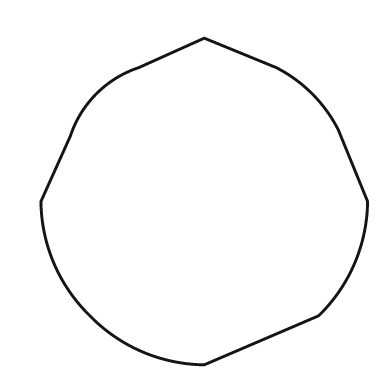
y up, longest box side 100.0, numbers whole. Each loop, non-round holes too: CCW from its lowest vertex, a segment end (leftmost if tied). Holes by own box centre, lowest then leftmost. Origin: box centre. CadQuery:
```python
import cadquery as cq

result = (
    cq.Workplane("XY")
    .moveTo(0.0, -50.0)
    .lineTo(35.0, -35.0)
    .threePointArc((46.0, -19.0), (50.0, 0.0))
    .lineTo(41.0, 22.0)
    .threePointArc((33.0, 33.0), (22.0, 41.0))
    .lineTo(0.0, 50.0)
    .lineTo(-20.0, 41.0)
    .threePointArc((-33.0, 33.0), (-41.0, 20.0))
    .lineTo(-50.0, 0.0)
    .threePointArc((-46.0, -19.0), (-35.0, -35.0))
    .threePointArc((-19.0, -46.0), (0.0, -50.0))
    .close()
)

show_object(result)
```